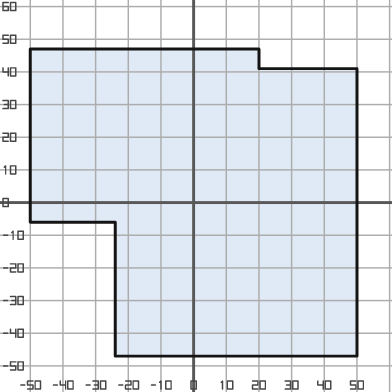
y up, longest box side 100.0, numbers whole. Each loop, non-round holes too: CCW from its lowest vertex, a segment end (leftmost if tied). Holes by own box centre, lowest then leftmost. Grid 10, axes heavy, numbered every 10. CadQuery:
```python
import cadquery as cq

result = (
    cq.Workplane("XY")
    .moveTo(-24.0, -47.0)
    .lineTo(50.0, -47.0)
    .lineTo(50.0, 41.0)
    .lineTo(20.0, 41.0)
    .lineTo(20.0, 47.0)
    .lineTo(-50.0, 47.0)
    .lineTo(-50.0, -6.0)
    .lineTo(-24.0, -6.0)
    .close()
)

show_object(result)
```